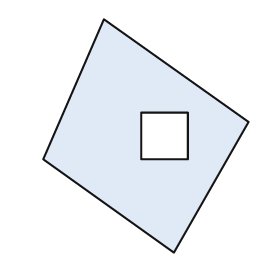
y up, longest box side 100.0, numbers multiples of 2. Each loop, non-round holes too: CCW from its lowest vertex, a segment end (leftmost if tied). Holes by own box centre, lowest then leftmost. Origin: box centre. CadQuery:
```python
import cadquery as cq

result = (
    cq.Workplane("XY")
    .moveTo(12.0, -50.0)
    .lineTo(44.0, 6.0)
    .lineTo(-18.0, 50.0)
    .lineTo(-44.0, -10.0)
    .close()
    .moveTo(-2.0, -10.0)
    .lineTo(18.0, -10.0)
    .lineTo(18.0, 10.0)
    .lineTo(-2.0, 10.0)
    .close()
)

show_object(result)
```